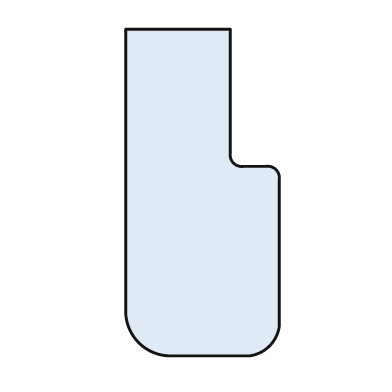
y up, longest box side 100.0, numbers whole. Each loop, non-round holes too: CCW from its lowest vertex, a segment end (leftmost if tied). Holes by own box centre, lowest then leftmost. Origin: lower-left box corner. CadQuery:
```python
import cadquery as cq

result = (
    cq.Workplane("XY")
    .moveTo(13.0, 0.0)
    .lineTo(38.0, 0.0)
    .threePointArc((44.0, 3.0), (47.0, 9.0))
    .lineTo(47.0, 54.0)
    .threePointArc((46.0, 57.0), (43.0, 58.0))
    .lineTo(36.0, 58.0)
    .threePointArc((33.0, 59.0), (32.0, 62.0))
    .lineTo(32.0, 100.0)
    .lineTo(0.0, 100.0)
    .lineTo(0.0, 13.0)
    .threePointArc((4.0, 4.0), (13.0, 0.0))
    .close()
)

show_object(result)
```